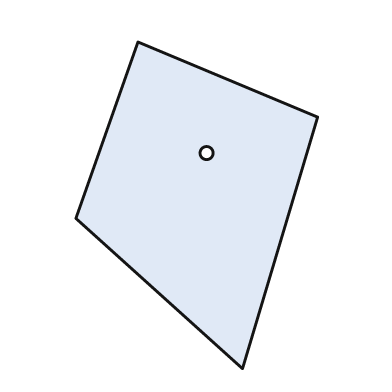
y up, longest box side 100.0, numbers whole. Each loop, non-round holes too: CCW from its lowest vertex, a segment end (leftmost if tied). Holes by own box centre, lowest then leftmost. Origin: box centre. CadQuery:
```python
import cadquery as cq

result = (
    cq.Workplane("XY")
    .moveTo(14.0, -50.0)
    .lineTo(37.0, 27.0)
    .lineTo(-18.0, 50.0)
    .lineTo(-37.0, -4.0)
    .close()
    .moveTo(3.0, 16.0)
    .circle(2.0)
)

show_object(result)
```